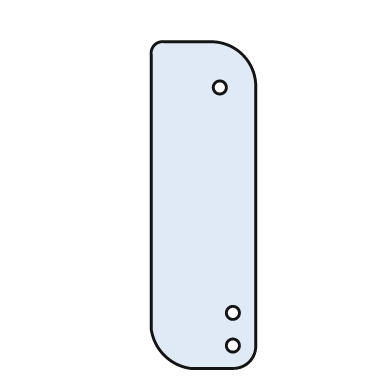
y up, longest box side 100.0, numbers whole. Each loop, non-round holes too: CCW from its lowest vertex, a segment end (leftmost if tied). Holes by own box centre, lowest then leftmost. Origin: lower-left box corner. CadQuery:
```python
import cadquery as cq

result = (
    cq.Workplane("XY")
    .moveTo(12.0, 0.0)
    .lineTo(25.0, 0.0)
    .threePointArc((30.0, 2.0), (32.0, 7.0))
    .lineTo(32.0, 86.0)
    .threePointArc((28.0, 96.0), (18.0, 100.0))
    .lineTo(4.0, 100.0)
    .threePointArc((1.0, 99.0), (0.0, 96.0))
    .lineTo(0.0, 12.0)
    .threePointArc((4.0, 4.0), (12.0, 0.0))
    .close()
    .moveTo(25.0, 7.0)
    .circle(2.0)
    .moveTo(25.0, 17.0)
    .circle(2.0)
    .moveTo(21.0, 86.0)
    .circle(2.0)
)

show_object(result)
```